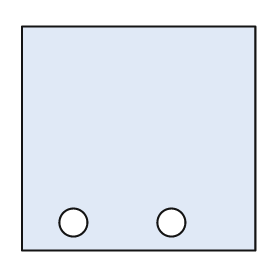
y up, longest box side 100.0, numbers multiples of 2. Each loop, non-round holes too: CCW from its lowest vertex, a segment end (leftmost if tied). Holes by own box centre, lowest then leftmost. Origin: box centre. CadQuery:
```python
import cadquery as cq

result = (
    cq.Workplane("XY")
    .moveTo(-50.0, -48.0)
    .lineTo(50.0, -48.0)
    .lineTo(50.0, 48.0)
    .lineTo(-50.0, 48.0)
    .close()
    .moveTo(-28.0, -36.0)
    .circle(6.0)
    .moveTo(14.0, -36.0)
    .circle(6.0)
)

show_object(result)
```